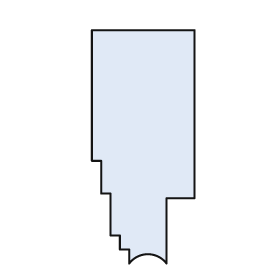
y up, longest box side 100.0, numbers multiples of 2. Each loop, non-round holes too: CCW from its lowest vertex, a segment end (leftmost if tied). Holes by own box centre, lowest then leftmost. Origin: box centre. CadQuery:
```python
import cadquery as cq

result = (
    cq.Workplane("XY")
    .moveTo(-6.0, -50.0)
    .threePointArc((2.0, -46.0), (10.0, -50.0))
    .lineTo(10.0, -22.0)
    .lineTo(22.0, -22.0)
    .lineTo(22.0, 50.0)
    .lineTo(-22.0, 50.0)
    .lineTo(-22.0, -6.0)
    .lineTo(-18.0, -6.0)
    .lineTo(-18.0, -20.0)
    .lineTo(-14.0, -20.0)
    .lineTo(-14.0, -38.0)
    .lineTo(-10.0, -38.0)
    .lineTo(-10.0, -44.0)
    .lineTo(-6.0, -44.0)
    .close()
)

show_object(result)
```